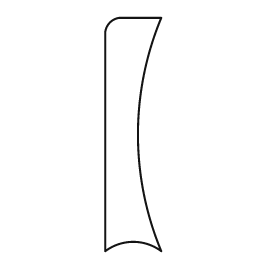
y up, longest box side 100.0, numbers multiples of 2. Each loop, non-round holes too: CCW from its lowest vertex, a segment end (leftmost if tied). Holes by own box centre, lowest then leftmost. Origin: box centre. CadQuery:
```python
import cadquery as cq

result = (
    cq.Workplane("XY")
    .moveTo(-12.0, -50.0)
    .threePointArc((0.0, -46.0), (12.0, -50.0))
    .threePointArc((2.0, 0.0), (12.0, 50.0))
    .lineTo(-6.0, 50.0)
    .threePointArc((-10.0, 48.0), (-12.0, 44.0))
    .close()
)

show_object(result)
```